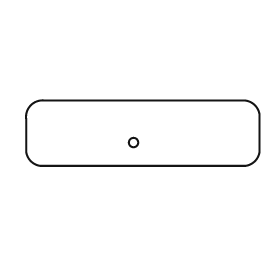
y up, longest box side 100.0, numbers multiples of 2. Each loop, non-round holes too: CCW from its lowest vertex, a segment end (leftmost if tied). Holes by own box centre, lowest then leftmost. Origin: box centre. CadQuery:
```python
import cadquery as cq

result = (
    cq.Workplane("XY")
    .moveTo(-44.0, -14.0)
    .lineTo(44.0, -14.0)
    .threePointArc((48.0, -12.0), (50.0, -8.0))
    .lineTo(50.0, 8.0)
    .threePointArc((48.0, 12.0), (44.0, 14.0))
    .lineTo(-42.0, 14.0)
    .threePointArc((-48.0, 12.0), (-50.0, 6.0))
    .lineTo(-50.0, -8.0)
    .threePointArc((-48.0, -12.0), (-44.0, -14.0))
    .close()
    .moveTo(-4.0, -4.0)
    .circle(2.0)
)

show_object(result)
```